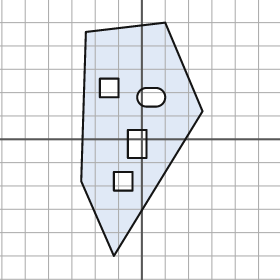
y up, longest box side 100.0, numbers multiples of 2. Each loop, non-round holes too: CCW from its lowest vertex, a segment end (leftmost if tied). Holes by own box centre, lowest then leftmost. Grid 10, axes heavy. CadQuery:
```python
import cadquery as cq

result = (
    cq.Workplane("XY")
    .moveTo(-12.0, -50.0)
    .lineTo(26.0, 12.0)
    .lineTo(10.0, 50.0)
    .lineTo(-24.0, 46.0)
    .lineTo(-26.0, -18.0)
    .close()
    .moveTo(-12.0, -22.0)
    .lineTo(-4.0, -22.0)
    .lineTo(-4.0, -14.0)
    .lineTo(-12.0, -14.0)
    .close()
    .moveTo(-6.0, -8.0)
    .lineTo(2.0, -8.0)
    .lineTo(2.0, 4.0)
    .lineTo(-6.0, 4.0)
    .close()
    .moveTo(2.0, 14.0)
    .lineTo(6.0, 14.0)
    .threePointArc((10.0, 18.0), (6.0, 22.0))
    .lineTo(2.0, 22.0)
    .threePointArc((-2.0, 18.0), (2.0, 14.0))
    .close()
    .moveTo(-18.0, 18.0)
    .lineTo(-10.0, 18.0)
    .lineTo(-10.0, 26.0)
    .lineTo(-18.0, 26.0)
    .close()
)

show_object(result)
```